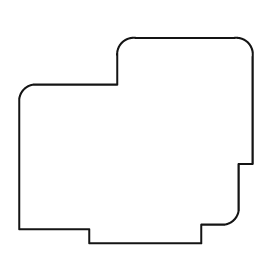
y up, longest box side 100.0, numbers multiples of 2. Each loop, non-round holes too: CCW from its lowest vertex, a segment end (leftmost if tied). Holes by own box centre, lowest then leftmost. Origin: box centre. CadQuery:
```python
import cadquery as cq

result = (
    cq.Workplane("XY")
    .moveTo(-20.0, -44.0)
    .lineTo(28.0, -44.0)
    .lineTo(28.0, -36.0)
    .lineTo(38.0, -36.0)
    .threePointArc((42.0, -34.0), (44.0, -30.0))
    .lineTo(44.0, -10.0)
    .lineTo(50.0, -10.0)
    .lineTo(50.0, 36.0)
    .threePointArc((48.0, 42.0), (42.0, 44.0))
    .lineTo(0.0, 44.0)
    .threePointArc((-6.0, 42.0), (-8.0, 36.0))
    .lineTo(-8.0, 24.0)
    .lineTo(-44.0, 24.0)
    .threePointArc((-48.0, 22.0), (-50.0, 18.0))
    .lineTo(-50.0, -38.0)
    .lineTo(-20.0, -38.0)
    .close()
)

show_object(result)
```